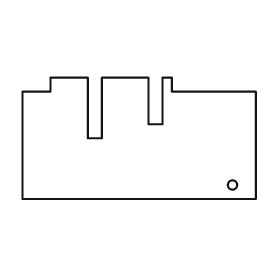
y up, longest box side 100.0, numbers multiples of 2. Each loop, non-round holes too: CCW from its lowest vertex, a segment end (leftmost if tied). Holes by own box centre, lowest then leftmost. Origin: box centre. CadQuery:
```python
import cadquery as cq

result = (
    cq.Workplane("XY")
    .moveTo(-50.0, -26.0)
    .lineTo(50.0, -26.0)
    .lineTo(50.0, 20.0)
    .lineTo(14.0, 20.0)
    .lineTo(14.0, 26.0)
    .lineTo(10.0, 26.0)
    .lineTo(10.0, 6.0)
    .lineTo(4.0, 6.0)
    .lineTo(4.0, 26.0)
    .lineTo(-16.0, 26.0)
    .lineTo(-16.0, 0.0)
    .lineTo(-22.0, 0.0)
    .lineTo(-22.0, 26.0)
    .lineTo(-38.0, 26.0)
    .lineTo(-38.0, 20.0)
    .lineTo(-50.0, 20.0)
    .close()
    .moveTo(40.0, -20.0)
    .circle(2.0)
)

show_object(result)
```